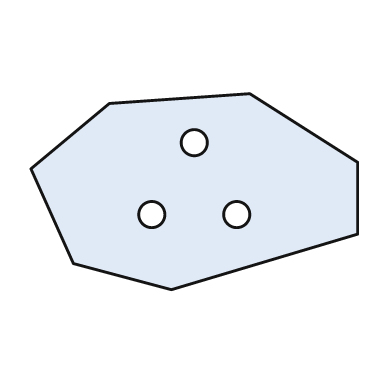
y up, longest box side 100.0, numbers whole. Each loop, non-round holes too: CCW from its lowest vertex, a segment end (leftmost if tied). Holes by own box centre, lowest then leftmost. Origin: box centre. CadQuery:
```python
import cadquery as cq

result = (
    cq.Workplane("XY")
    .moveTo(-7.0, -30.0)
    .lineTo(50.0, -13.0)
    .lineTo(50.0, 9.0)
    .lineTo(17.0, 30.0)
    .lineTo(-26.0, 27.0)
    .lineTo(-50.0, 7.0)
    .lineTo(-37.0, -22.0)
    .close()
    .moveTo(-13.0, -7.0)
    .circle(4.0)
    .moveTo(13.0, -7.0)
    .circle(4.0)
    .moveTo(0.0, 15.0)
    .circle(4.0)
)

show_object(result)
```